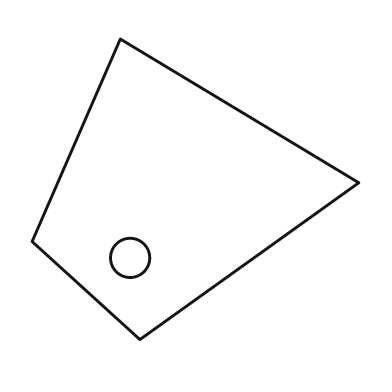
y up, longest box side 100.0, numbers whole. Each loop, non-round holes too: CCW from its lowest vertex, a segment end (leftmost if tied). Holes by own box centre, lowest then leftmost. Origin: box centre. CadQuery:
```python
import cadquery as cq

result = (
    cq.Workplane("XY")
    .moveTo(-17.0, -46.0)
    .lineTo(50.0, 2.0)
    .lineTo(-23.0, 46.0)
    .lineTo(-50.0, -16.0)
    .close()
    .moveTo(-20.0, -21.0)
    .circle(6.0)
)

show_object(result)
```